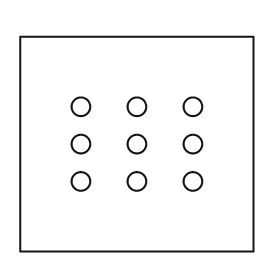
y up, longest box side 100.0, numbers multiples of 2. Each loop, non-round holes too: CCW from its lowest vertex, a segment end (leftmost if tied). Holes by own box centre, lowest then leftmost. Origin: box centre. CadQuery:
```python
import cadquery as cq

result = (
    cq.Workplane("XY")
    .moveTo(-50.0, -46.0)
    .lineTo(50.0, -46.0)
    .lineTo(50.0, 46.0)
    .lineTo(-50.0, 46.0)
    .close()
    .moveTo(-24.0, -16.0)
    .circle(4.0)
    .moveTo(0.0, -16.0)
    .circle(4.0)
    .moveTo(24.0, -16.0)
    .circle(4.0)
    .moveTo(-24.0, 0.0)
    .circle(4.0)
    .moveTo(0.0, 0.0)
    .circle(4.0)
    .moveTo(24.0, 0.0)
    .circle(4.0)
    .moveTo(-24.0, 16.0)
    .circle(4.0)
    .moveTo(0.0, 16.0)
    .circle(4.0)
    .moveTo(24.0, 16.0)
    .circle(4.0)
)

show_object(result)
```